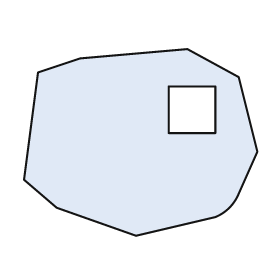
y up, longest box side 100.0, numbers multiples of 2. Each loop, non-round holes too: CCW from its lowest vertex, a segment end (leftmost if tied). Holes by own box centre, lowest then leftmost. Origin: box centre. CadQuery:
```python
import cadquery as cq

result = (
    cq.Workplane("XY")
    .moveTo(-2.0, -40.0)
    .lineTo(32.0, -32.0)
    .threePointArc((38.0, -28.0), (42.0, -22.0))
    .lineTo(50.0, -4.0)
    .lineTo(42.0, 28.0)
    .lineTo(20.0, 40.0)
    .lineTo(-26.0, 36.0)
    .lineTo(-44.0, 30.0)
    .lineTo(-50.0, -16.0)
    .lineTo(-36.0, -28.0)
    .close()
    .moveTo(12.0, 4.0)
    .lineTo(32.0, 4.0)
    .lineTo(32.0, 24.0)
    .lineTo(12.0, 24.0)
    .close()
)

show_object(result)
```